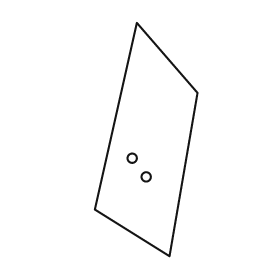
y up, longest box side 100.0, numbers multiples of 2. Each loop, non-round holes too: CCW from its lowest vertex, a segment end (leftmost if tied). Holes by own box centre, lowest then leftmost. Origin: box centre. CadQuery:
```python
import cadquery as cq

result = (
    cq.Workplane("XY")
    .moveTo(10.0, -50.0)
    .lineTo(22.0, 20.0)
    .lineTo(-4.0, 50.0)
    .lineTo(-22.0, -30.0)
    .close()
    .moveTo(0.0, -16.0)
    .circle(2.0)
    .moveTo(-6.0, -8.0)
    .circle(2.0)
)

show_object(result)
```